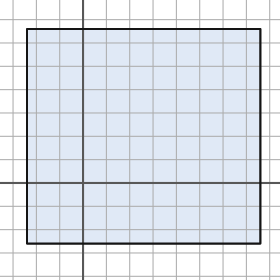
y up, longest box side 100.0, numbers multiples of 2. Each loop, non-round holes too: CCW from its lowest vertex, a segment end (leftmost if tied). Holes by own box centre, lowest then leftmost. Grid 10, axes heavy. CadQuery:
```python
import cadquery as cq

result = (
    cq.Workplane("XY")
    .moveTo(-24.0, -26.0)
    .lineTo(76.0, -26.0)
    .lineTo(76.0, 66.0)
    .lineTo(-24.0, 66.0)
    .close()
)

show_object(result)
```